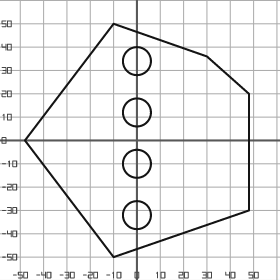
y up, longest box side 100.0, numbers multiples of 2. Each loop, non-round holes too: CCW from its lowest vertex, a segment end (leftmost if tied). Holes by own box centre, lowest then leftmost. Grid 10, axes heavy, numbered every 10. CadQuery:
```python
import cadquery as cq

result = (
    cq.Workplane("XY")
    .moveTo(-10.0, -50.0)
    .lineTo(48.0, -30.0)
    .lineTo(48.0, 20.0)
    .lineTo(30.0, 36.0)
    .lineTo(-10.0, 50.0)
    .lineTo(-48.0, 0.0)
    .close()
    .moveTo(0.0, -32.0)
    .circle(6.0)
    .moveTo(0.0, -10.0)
    .circle(6.0)
    .moveTo(0.0, 12.0)
    .circle(6.0)
    .moveTo(0.0, 34.0)
    .circle(6.0)
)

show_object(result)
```